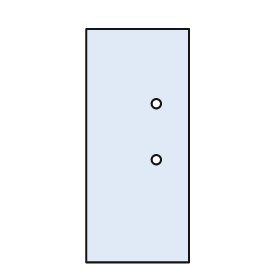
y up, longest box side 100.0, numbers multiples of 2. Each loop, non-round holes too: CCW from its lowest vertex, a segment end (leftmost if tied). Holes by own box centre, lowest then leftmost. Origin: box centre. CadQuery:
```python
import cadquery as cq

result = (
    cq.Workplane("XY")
    .moveTo(-22.0, -50.0)
    .lineTo(22.0, -50.0)
    .lineTo(22.0, 50.0)
    .lineTo(-22.0, 50.0)
    .close()
    .moveTo(8.0, -6.0)
    .circle(2.0)
    .moveTo(8.0, 18.0)
    .circle(2.0)
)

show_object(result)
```